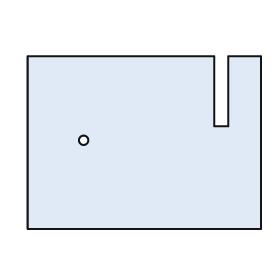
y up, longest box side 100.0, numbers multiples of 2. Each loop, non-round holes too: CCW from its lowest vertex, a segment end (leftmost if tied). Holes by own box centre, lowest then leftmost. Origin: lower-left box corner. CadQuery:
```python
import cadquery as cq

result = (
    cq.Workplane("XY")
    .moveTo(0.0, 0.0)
    .lineTo(100.0, 0.0)
    .lineTo(100.0, 74.0)
    .lineTo(86.0, 74.0)
    .lineTo(86.0, 44.0)
    .lineTo(80.0, 44.0)
    .lineTo(80.0, 74.0)
    .lineTo(0.0, 74.0)
    .close()
    .moveTo(24.0, 38.0)
    .circle(2.0)
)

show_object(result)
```